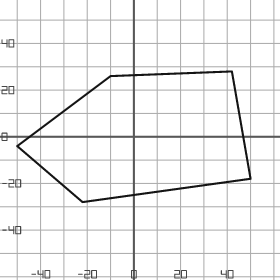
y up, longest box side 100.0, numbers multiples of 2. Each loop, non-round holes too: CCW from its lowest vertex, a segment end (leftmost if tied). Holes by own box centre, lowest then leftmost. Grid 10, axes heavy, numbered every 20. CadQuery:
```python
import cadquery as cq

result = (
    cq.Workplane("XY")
    .moveTo(-22.0, -28.0)
    .lineTo(50.0, -18.0)
    .lineTo(42.0, 28.0)
    .lineTo(-10.0, 26.0)
    .lineTo(-50.0, -4.0)
    .close()
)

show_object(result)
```